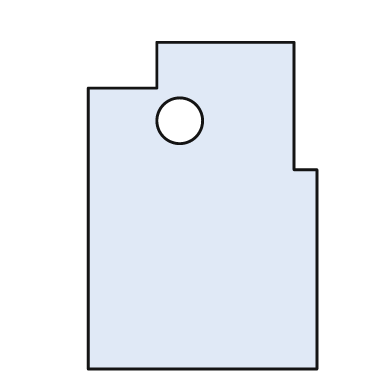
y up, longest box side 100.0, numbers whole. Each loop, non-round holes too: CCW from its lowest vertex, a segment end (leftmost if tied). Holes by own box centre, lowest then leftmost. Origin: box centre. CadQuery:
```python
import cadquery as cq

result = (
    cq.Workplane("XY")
    .moveTo(-35.0, -50.0)
    .lineTo(35.0, -50.0)
    .lineTo(35.0, 11.0)
    .lineTo(28.0, 11.0)
    .lineTo(28.0, 50.0)
    .lineTo(-14.0, 50.0)
    .lineTo(-14.0, 36.0)
    .lineTo(-35.0, 36.0)
    .close()
    .moveTo(-7.0, 26.0)
    .circle(7.0)
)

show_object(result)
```